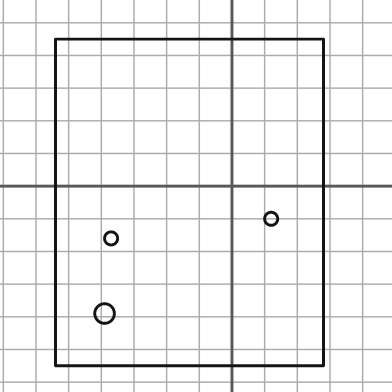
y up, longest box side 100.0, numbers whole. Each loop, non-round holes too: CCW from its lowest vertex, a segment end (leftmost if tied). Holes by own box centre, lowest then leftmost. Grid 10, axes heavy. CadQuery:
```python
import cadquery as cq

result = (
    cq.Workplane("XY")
    .moveTo(-54.0, -55.0)
    .lineTo(28.0, -55.0)
    .lineTo(28.0, 45.0)
    .lineTo(-54.0, 45.0)
    .close()
    .moveTo(-39.0, -39.0)
    .circle(3.0)
    .moveTo(-37.0, -16.0)
    .circle(2.0)
    .moveTo(12.0, -10.0)
    .circle(2.0)
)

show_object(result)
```